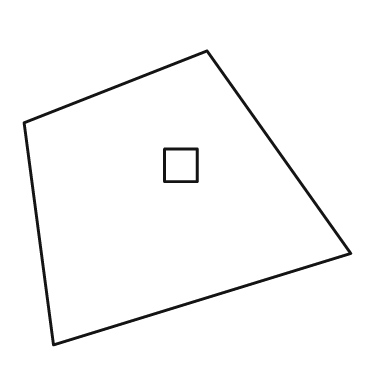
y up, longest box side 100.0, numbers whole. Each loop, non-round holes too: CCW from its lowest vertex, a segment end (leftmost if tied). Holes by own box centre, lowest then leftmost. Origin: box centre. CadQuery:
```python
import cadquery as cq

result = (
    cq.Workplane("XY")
    .moveTo(-41.0, -45.0)
    .lineTo(50.0, -17.0)
    .lineTo(6.0, 45.0)
    .lineTo(-50.0, 23.0)
    .close()
    .moveTo(-7.0, 5.0)
    .lineTo(3.0, 5.0)
    .lineTo(3.0, 15.0)
    .lineTo(-7.0, 15.0)
    .close()
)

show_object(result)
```